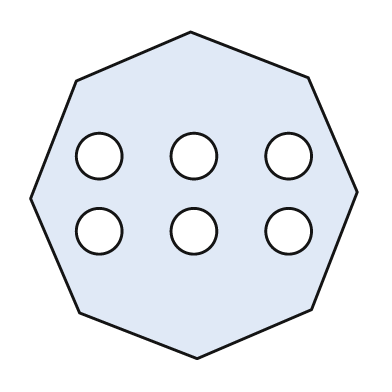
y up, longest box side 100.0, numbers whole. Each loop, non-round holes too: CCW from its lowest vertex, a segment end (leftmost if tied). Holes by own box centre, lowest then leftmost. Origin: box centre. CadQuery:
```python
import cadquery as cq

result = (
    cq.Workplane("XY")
    .moveTo(1.0, -50.0)
    .lineTo(36.0, -35.0)
    .lineTo(50.0, 1.0)
    .lineTo(35.0, 36.0)
    .lineTo(-1.0, 50.0)
    .lineTo(-36.0, 35.0)
    .lineTo(-50.0, -1.0)
    .lineTo(-35.0, -36.0)
    .close()
    .moveTo(-29.0, -11.0)
    .circle(7.0)
    .moveTo(0.0, -11.0)
    .circle(7.0)
    .moveTo(29.0, -11.0)
    .circle(7.0)
    .moveTo(-29.0, 12.0)
    .circle(7.0)
    .moveTo(0.0, 12.0)
    .circle(7.0)
    .moveTo(29.0, 12.0)
    .circle(7.0)
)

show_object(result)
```